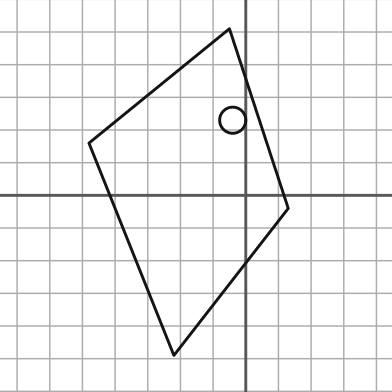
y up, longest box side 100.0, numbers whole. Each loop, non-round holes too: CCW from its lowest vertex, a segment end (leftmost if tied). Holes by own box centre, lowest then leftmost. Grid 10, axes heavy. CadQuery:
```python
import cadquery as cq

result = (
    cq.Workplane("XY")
    .moveTo(-22.0, -49.0)
    .lineTo(13.0, -4.0)
    .lineTo(-5.0, 51.0)
    .lineTo(-48.0, 16.0)
    .close()
    .moveTo(-4.0, 23.0)
    .circle(4.0)
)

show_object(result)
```